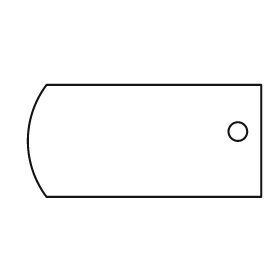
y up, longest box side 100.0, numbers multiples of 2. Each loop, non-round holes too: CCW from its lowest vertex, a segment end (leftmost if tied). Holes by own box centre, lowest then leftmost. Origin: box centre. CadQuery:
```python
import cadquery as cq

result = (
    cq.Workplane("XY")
    .moveTo(-42.0, -24.0)
    .lineTo(50.0, -24.0)
    .lineTo(50.0, 24.0)
    .lineTo(-42.0, 24.0)
    .threePointArc((-50.0, 0.0), (-42.0, -24.0))
    .close()
    .moveTo(40.0, 4.0)
    .circle(4.0)
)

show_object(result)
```